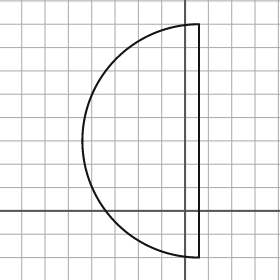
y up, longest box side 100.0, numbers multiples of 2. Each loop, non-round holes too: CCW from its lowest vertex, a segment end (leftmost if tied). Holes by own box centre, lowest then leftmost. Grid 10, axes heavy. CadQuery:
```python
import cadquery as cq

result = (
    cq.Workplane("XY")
    .moveTo(6.0, -20.0)
    .lineTo(6.0, 80.0)
    .threePointArc((-44.0, 30.0), (6.0, -20.0))
    .close()
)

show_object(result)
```